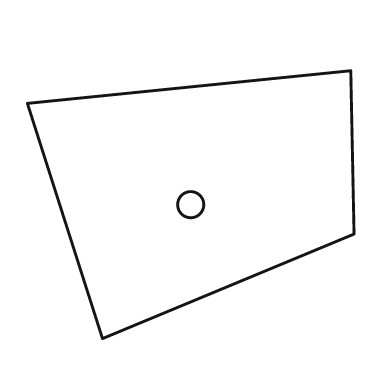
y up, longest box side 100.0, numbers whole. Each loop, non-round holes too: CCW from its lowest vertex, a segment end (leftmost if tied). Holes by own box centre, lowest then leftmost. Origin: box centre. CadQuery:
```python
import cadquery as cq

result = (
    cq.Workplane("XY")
    .moveTo(-27.0, -41.0)
    .lineTo(50.0, -9.0)
    .lineTo(49.0, 41.0)
    .lineTo(-50.0, 31.0)
    .close()
    .moveTo(0.0, 0.0)
    .circle(4.0)
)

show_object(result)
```